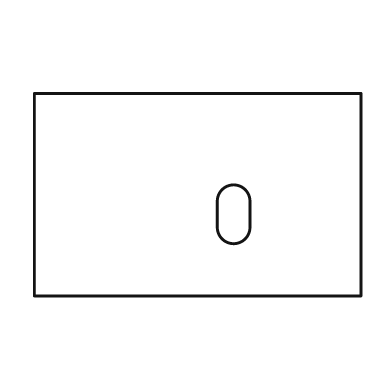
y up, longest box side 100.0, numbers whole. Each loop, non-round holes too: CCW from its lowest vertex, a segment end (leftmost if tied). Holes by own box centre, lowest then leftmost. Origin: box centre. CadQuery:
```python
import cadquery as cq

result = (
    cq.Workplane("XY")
    .moveTo(-50.0, -31.0)
    .lineTo(50.0, -31.0)
    .lineTo(50.0, 31.0)
    .lineTo(-50.0, 31.0)
    .close()
    .moveTo(6.0, -10.0)
    .threePointArc((11.0, -15.0), (16.0, -10.0))
    .lineTo(16.0, -2.0)
    .threePointArc((11.0, 3.0), (6.0, -2.0))
    .close()
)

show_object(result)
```